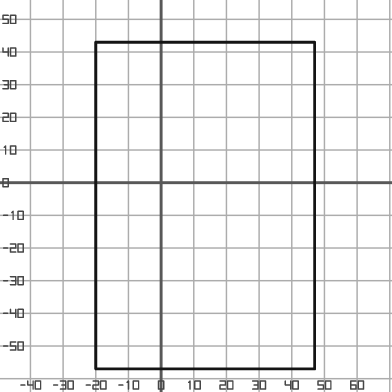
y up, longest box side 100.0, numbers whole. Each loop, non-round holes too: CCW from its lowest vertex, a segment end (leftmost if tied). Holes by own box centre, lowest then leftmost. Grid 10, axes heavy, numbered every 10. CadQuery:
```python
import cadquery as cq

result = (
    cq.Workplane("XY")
    .moveTo(-20.0, -57.0)
    .lineTo(47.0, -57.0)
    .lineTo(47.0, 43.0)
    .lineTo(-20.0, 43.0)
    .close()
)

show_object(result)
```